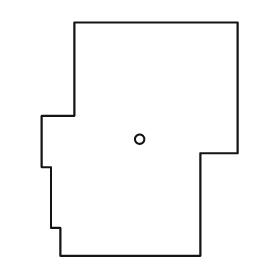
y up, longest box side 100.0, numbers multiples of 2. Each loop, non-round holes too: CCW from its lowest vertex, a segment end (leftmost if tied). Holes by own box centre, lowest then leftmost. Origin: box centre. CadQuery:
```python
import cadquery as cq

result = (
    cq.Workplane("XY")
    .moveTo(-34.0, -50.0)
    .lineTo(26.0, -50.0)
    .lineTo(26.0, -6.0)
    .lineTo(42.0, -6.0)
    .lineTo(42.0, 50.0)
    .lineTo(-28.0, 50.0)
    .lineTo(-28.0, 10.0)
    .lineTo(-42.0, 10.0)
    .lineTo(-42.0, -12.0)
    .lineTo(-38.0, -12.0)
    .lineTo(-38.0, -38.0)
    .lineTo(-34.0, -38.0)
    .close()
    .moveTo(0.0, 0.0)
    .circle(2.0)
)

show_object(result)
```